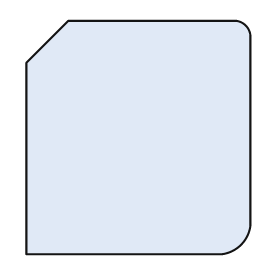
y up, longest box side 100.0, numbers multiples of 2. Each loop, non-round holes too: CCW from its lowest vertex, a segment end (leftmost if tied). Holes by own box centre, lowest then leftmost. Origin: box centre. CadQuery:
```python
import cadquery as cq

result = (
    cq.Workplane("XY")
    .moveTo(-48.0, -50.0)
    .lineTo(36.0, -50.0)
    .threePointArc((44.0, -46.0), (48.0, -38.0))
    .lineTo(48.0, 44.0)
    .threePointArc((46.0, 48.0), (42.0, 50.0))
    .lineTo(-30.0, 50.0)
    .lineTo(-48.0, 32.0)
    .close()
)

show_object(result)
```